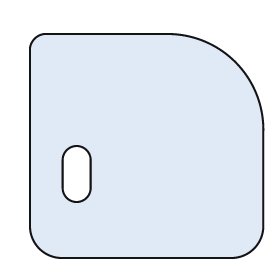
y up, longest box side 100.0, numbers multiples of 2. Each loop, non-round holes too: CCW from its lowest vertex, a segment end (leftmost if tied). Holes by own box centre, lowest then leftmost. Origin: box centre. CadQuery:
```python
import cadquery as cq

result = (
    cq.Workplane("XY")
    .moveTo(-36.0, -48.0)
    .lineTo(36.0, -48.0)
    .threePointArc((46.0, -44.0), (50.0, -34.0))
    .lineTo(50.0, 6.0)
    .threePointArc((38.0, 36.0), (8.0, 48.0))
    .lineTo(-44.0, 48.0)
    .threePointArc((-48.0, 46.0), (-50.0, 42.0))
    .lineTo(-50.0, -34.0)
    .threePointArc((-46.0, -44.0), (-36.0, -48.0))
    .close()
    .moveTo(-36.0, -18.0)
    .threePointArc((-30.0, -24.0), (-24.0, -18.0))
    .lineTo(-24.0, -6.0)
    .threePointArc((-30.0, 0.0), (-36.0, -6.0))
    .close()
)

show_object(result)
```